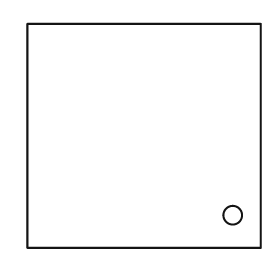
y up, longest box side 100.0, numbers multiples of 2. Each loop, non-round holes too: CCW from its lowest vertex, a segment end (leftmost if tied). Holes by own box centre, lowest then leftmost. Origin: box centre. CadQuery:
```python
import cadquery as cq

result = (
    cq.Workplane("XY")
    .moveTo(-50.0, -48.0)
    .lineTo(50.0, -48.0)
    .lineTo(50.0, 48.0)
    .lineTo(-50.0, 48.0)
    .close()
    .moveTo(38.0, -34.0)
    .circle(4.0)
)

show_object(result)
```